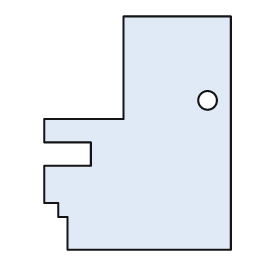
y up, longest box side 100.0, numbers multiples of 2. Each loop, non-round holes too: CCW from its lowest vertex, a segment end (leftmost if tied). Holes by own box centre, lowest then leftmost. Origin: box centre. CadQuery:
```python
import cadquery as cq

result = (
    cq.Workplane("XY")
    .moveTo(-30.0, -50.0)
    .lineTo(40.0, -50.0)
    .lineTo(40.0, 50.0)
    .lineTo(-6.0, 50.0)
    .lineTo(-6.0, 6.0)
    .lineTo(-40.0, 6.0)
    .lineTo(-40.0, -4.0)
    .lineTo(-20.0, -4.0)
    .lineTo(-20.0, -14.0)
    .lineTo(-40.0, -14.0)
    .lineTo(-40.0, -30.0)
    .lineTo(-34.0, -30.0)
    .lineTo(-34.0, -36.0)
    .lineTo(-30.0, -36.0)
    .close()
    .moveTo(30.0, 14.0)
    .circle(4.0)
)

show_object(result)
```